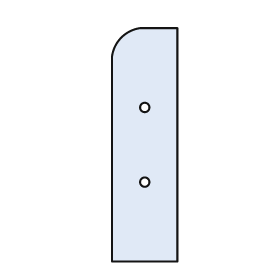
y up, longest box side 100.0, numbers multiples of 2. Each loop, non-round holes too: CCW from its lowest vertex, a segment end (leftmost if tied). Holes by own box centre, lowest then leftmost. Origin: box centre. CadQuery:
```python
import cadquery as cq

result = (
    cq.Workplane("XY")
    .moveTo(-14.0, -50.0)
    .lineTo(14.0, -50.0)
    .lineTo(14.0, 50.0)
    .lineTo(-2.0, 50.0)
    .threePointArc((-10.0, 46.0), (-14.0, 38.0))
    .close()
    .moveTo(0.0, -16.0)
    .circle(2.0)
    .moveTo(0.0, 16.0)
    .circle(2.0)
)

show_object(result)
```